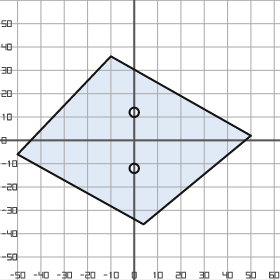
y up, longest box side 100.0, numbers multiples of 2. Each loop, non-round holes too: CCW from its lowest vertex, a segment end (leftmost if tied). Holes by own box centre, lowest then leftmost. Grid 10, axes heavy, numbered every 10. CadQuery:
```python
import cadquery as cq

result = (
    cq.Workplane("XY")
    .moveTo(4.0, -36.0)
    .lineTo(50.0, 2.0)
    .lineTo(-10.0, 36.0)
    .lineTo(-50.0, -6.0)
    .close()
    .moveTo(0.0, -12.0)
    .circle(2.0)
    .moveTo(0.0, 12.0)
    .circle(2.0)
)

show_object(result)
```